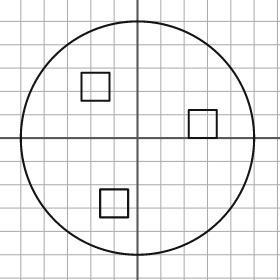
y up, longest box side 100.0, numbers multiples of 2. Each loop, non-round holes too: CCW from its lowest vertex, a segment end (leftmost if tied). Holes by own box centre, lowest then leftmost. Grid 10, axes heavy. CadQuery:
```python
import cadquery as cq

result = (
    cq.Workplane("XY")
    .moveTo(0.0, 0.0)
    .circle(50.0)
    .moveTo(-16.0, -34.0)
    .lineTo(-4.0, -34.0)
    .lineTo(-4.0, -22.0)
    .lineTo(-16.0, -22.0)
    .close()
    .moveTo(22.0, 0.0)
    .lineTo(34.0, 0.0)
    .lineTo(34.0, 12.0)
    .lineTo(22.0, 12.0)
    .close()
    .moveTo(-24.0, 16.0)
    .lineTo(-12.0, 16.0)
    .lineTo(-12.0, 28.0)
    .lineTo(-24.0, 28.0)
    .close()
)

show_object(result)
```